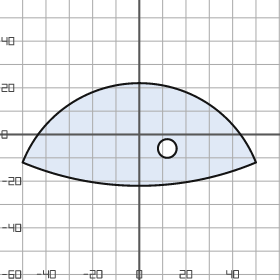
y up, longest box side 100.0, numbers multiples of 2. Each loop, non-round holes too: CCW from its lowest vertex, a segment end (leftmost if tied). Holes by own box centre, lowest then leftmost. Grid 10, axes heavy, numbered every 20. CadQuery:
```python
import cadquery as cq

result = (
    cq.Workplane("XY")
    .moveTo(-50.0, -12.0)
    .threePointArc((0.0, -22.0), (50.0, -12.0))
    .threePointArc((0.0, 22.0), (-50.0, -12.0))
    .close()
    .moveTo(12.0, -6.0)
    .circle(4.0)
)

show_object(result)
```